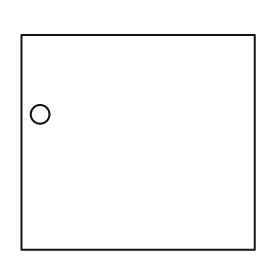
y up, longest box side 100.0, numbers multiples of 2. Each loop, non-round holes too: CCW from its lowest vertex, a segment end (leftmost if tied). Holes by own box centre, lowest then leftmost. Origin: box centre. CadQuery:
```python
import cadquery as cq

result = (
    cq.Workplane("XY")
    .moveTo(-50.0, -46.0)
    .lineTo(50.0, -46.0)
    .lineTo(50.0, 46.0)
    .lineTo(-50.0, 46.0)
    .close()
    .moveTo(-42.0, 12.0)
    .circle(4.0)
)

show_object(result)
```